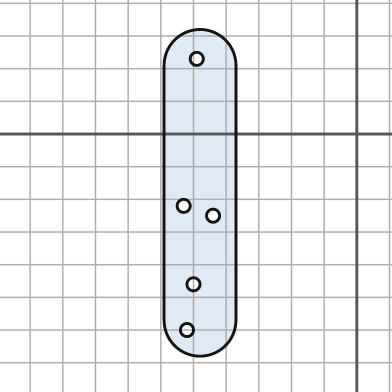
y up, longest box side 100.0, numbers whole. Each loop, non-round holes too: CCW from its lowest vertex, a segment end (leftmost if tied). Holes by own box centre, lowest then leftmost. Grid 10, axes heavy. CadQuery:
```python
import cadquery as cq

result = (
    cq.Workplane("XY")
    .moveTo(-59.0, -57.0)
    .threePointArc((-48.0, -68.0), (-37.0, -57.0))
    .lineTo(-37.0, 21.0)
    .threePointArc((-48.0, 32.0), (-59.0, 21.0))
    .close()
    .moveTo(-52.0, -60.0)
    .circle(2.0)
    .moveTo(-50.0, -46.0)
    .circle(2.0)
    .moveTo(-44.0, -25.0)
    .circle(2.0)
    .moveTo(-53.0, -22.0)
    .circle(2.0)
    .moveTo(-49.0, 23.0)
    .circle(2.0)
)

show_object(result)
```